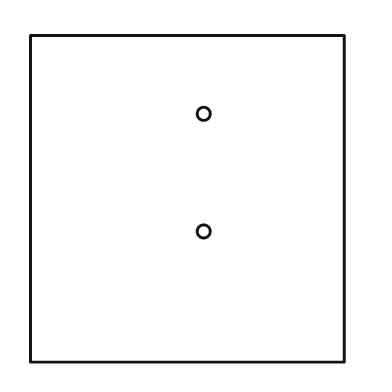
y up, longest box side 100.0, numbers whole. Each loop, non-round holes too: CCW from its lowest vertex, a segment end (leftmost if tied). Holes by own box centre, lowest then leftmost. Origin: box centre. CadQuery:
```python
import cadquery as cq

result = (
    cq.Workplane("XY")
    .moveTo(-48.0, -50.0)
    .lineTo(48.0, -50.0)
    .lineTo(48.0, 50.0)
    .lineTo(-48.0, 50.0)
    .close()
    .moveTo(5.0, -10.0)
    .circle(2.0)
    .moveTo(5.0, 26.0)
    .circle(2.0)
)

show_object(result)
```